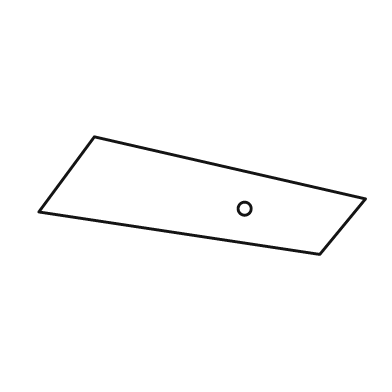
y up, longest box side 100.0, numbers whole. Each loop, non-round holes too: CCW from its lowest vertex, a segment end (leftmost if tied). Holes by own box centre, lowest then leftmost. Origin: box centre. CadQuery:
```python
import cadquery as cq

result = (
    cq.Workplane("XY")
    .moveTo(36.0, -18.0)
    .lineTo(50.0, -1.0)
    .lineTo(-33.0, 18.0)
    .lineTo(-50.0, -5.0)
    .close()
    .moveTo(13.0, -4.0)
    .circle(2.0)
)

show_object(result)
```